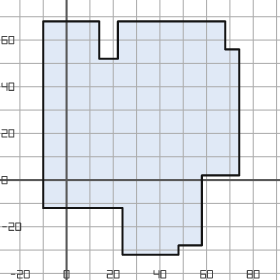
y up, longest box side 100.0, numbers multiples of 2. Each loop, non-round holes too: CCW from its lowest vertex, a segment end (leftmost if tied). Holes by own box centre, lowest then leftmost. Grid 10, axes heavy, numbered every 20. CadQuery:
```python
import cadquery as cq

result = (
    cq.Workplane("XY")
    .moveTo(24.0, -32.0)
    .lineTo(48.0, -32.0)
    .lineTo(48.0, -28.0)
    .lineTo(58.0, -28.0)
    .lineTo(58.0, 2.0)
    .lineTo(74.0, 2.0)
    .lineTo(74.0, 56.0)
    .lineTo(68.0, 56.0)
    .lineTo(68.0, 68.0)
    .lineTo(22.0, 68.0)
    .lineTo(22.0, 52.0)
    .lineTo(14.0, 52.0)
    .lineTo(14.0, 68.0)
    .lineTo(-10.0, 68.0)
    .lineTo(-10.0, -12.0)
    .lineTo(24.0, -12.0)
    .close()
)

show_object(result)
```